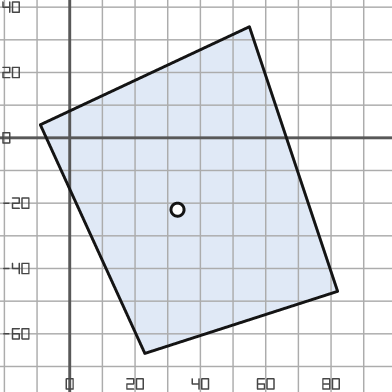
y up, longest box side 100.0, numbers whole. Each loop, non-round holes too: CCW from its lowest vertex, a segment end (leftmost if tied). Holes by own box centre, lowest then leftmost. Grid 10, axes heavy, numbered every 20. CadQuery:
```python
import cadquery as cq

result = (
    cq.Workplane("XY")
    .moveTo(23.0, -66.0)
    .lineTo(82.0, -47.0)
    .lineTo(55.0, 34.0)
    .lineTo(-9.0, 4.0)
    .close()
    .moveTo(33.0, -22.0)
    .circle(2.0)
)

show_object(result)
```